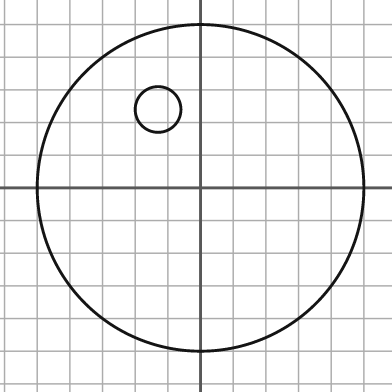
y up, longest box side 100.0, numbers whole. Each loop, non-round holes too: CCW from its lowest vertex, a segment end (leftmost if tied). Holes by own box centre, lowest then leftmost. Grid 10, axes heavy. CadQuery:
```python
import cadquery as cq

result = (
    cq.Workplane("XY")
    .moveTo(0.0, 0.0)
    .circle(50.0)
    .moveTo(-13.0, 24.0)
    .circle(7.0)
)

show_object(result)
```